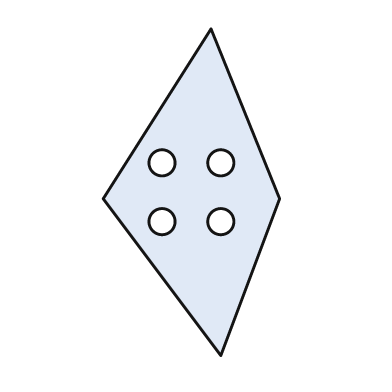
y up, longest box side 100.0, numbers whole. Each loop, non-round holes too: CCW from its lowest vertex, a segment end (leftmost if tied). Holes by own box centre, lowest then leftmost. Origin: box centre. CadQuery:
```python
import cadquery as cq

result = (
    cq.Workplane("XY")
    .moveTo(9.0, -50.0)
    .lineTo(27.0, -2.0)
    .lineTo(6.0, 50.0)
    .lineTo(-27.0, -2.0)
    .close()
    .moveTo(-9.0, -9.0)
    .circle(4.0)
    .moveTo(9.0, -9.0)
    .circle(4.0)
    .moveTo(-9.0, 9.0)
    .circle(4.0)
    .moveTo(9.0, 9.0)
    .circle(4.0)
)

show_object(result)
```